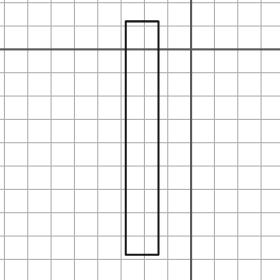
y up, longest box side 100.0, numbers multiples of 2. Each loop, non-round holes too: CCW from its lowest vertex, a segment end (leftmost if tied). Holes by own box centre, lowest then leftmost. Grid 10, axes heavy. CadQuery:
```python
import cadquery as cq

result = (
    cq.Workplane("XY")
    .moveTo(-28.0, -88.0)
    .lineTo(-14.0, -88.0)
    .lineTo(-14.0, 12.0)
    .lineTo(-28.0, 12.0)
    .close()
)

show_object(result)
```